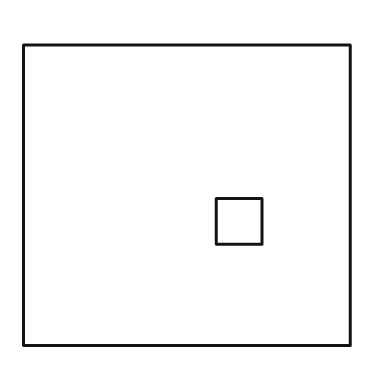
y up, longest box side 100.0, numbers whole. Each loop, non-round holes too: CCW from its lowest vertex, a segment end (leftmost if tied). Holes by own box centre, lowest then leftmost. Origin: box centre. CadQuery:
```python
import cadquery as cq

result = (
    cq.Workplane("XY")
    .moveTo(-50.0, -46.0)
    .lineTo(50.0, -46.0)
    .lineTo(50.0, 46.0)
    .lineTo(-50.0, 46.0)
    .close()
    .moveTo(9.0, -15.0)
    .lineTo(23.0, -15.0)
    .lineTo(23.0, -1.0)
    .lineTo(9.0, -1.0)
    .close()
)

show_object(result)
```